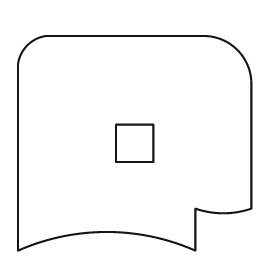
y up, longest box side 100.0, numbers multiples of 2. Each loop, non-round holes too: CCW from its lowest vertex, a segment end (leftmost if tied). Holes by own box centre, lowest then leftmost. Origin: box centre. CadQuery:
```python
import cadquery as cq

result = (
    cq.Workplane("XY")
    .moveTo(-50.0, -46.0)
    .threePointArc((-12.0, -38.0), (26.0, -46.0))
    .lineTo(26.0, -28.0)
    .threePointArc((38.0, -30.0), (50.0, -28.0))
    .lineTo(50.0, 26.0)
    .threePointArc((44.0, 40.0), (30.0, 46.0))
    .lineTo(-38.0, 46.0)
    .threePointArc((-46.0, 42.0), (-50.0, 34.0))
    .close()
    .moveTo(-8.0, -8.0)
    .lineTo(8.0, -8.0)
    .lineTo(8.0, 8.0)
    .lineTo(-8.0, 8.0)
    .close()
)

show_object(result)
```